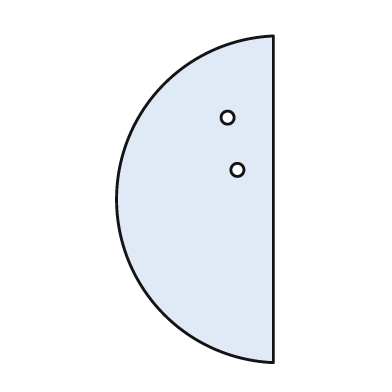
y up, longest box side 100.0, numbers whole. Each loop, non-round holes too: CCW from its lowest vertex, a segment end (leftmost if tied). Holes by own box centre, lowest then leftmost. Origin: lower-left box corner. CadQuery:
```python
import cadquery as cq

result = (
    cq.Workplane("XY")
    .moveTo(48.0, 0.0)
    .lineTo(48.0, 100.0)
    .threePointArc((0.0, 50.0), (48.0, 0.0))
    .close()
    .moveTo(37.0, 59.0)
    .circle(2.0)
    .moveTo(34.0, 75.0)
    .circle(2.0)
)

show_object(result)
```